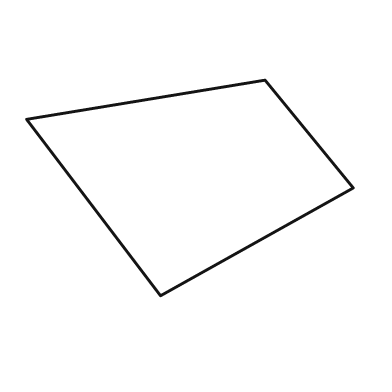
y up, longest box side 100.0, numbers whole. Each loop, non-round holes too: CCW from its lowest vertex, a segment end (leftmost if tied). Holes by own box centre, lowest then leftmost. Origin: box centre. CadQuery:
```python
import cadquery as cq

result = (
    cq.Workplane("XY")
    .moveTo(-9.0, -33.0)
    .lineTo(50.0, 0.0)
    .lineTo(23.0, 33.0)
    .lineTo(-50.0, 21.0)
    .close()
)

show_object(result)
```